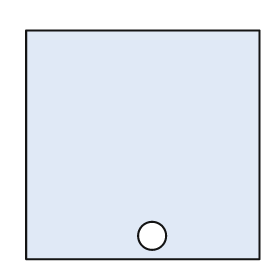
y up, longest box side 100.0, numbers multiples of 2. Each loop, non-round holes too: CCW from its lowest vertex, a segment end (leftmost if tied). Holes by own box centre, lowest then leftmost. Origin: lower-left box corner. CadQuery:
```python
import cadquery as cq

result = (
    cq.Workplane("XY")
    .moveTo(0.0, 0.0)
    .lineTo(100.0, 0.0)
    .lineTo(100.0, 98.0)
    .lineTo(0.0, 98.0)
    .close()
    .moveTo(54.0, 10.0)
    .circle(6.0)
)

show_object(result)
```